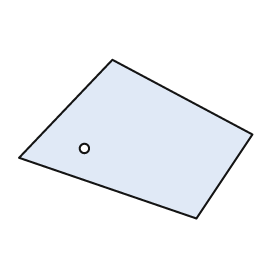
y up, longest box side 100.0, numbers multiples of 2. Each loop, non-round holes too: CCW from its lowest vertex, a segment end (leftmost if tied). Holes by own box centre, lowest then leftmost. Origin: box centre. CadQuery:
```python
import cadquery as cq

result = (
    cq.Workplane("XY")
    .moveTo(26.0, -34.0)
    .lineTo(50.0, 2.0)
    .lineTo(-10.0, 34.0)
    .lineTo(-50.0, -8.0)
    .close()
    .moveTo(-22.0, -4.0)
    .circle(2.0)
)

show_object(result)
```